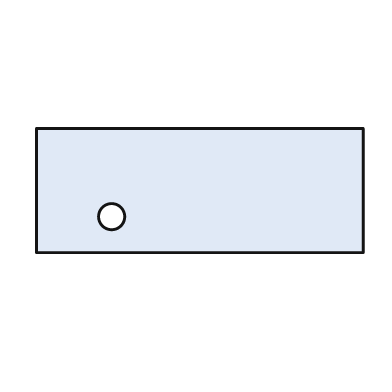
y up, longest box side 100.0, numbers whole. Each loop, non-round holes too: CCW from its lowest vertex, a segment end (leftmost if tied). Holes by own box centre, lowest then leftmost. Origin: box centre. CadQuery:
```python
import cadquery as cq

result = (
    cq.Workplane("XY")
    .moveTo(-50.0, -19.0)
    .lineTo(50.0, -19.0)
    .lineTo(50.0, 19.0)
    .lineTo(-50.0, 19.0)
    .close()
    .moveTo(-27.0, -8.0)
    .circle(4.0)
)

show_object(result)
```